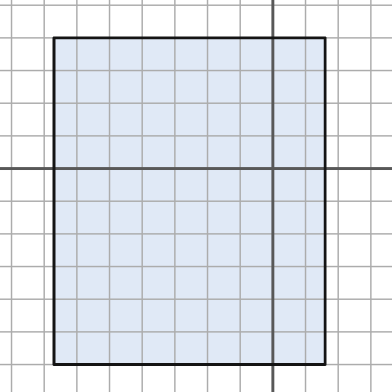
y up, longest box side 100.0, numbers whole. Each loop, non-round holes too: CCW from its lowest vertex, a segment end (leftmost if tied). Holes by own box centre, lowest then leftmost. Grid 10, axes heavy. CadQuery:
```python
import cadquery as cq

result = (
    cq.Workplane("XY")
    .moveTo(-67.0, -60.0)
    .lineTo(16.0, -60.0)
    .lineTo(16.0, 40.0)
    .lineTo(-67.0, 40.0)
    .close()
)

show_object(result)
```